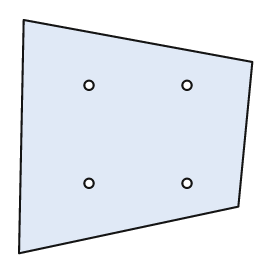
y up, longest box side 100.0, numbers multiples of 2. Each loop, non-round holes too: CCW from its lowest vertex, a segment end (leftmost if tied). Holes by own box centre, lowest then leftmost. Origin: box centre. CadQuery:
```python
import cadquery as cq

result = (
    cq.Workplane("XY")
    .moveTo(-50.0, -50.0)
    .lineTo(44.0, -30.0)
    .lineTo(50.0, 32.0)
    .lineTo(-48.0, 50.0)
    .close()
    .moveTo(-20.0, -20.0)
    .circle(2.0)
    .moveTo(22.0, -20.0)
    .circle(2.0)
    .moveTo(-20.0, 22.0)
    .circle(2.0)
    .moveTo(22.0, 22.0)
    .circle(2.0)
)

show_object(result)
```